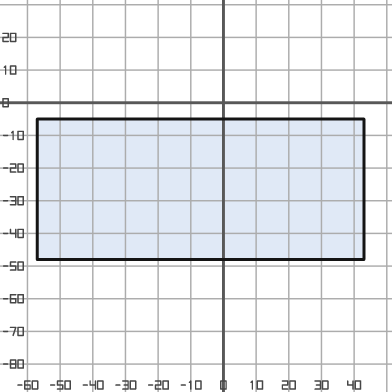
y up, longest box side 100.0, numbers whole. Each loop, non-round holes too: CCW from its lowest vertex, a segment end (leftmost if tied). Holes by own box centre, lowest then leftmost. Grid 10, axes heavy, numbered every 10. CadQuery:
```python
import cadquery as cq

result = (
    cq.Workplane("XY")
    .moveTo(-57.0, -48.0)
    .lineTo(43.0, -48.0)
    .lineTo(43.0, -5.0)
    .lineTo(-57.0, -5.0)
    .close()
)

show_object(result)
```